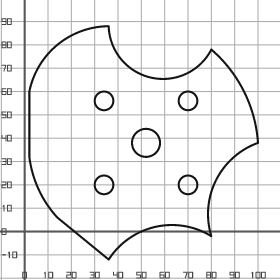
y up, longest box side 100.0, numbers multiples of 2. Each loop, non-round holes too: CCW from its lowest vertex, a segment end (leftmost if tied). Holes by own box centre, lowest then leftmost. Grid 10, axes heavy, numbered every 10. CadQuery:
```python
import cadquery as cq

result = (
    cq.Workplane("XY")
    .moveTo(36.0, -12.0)
    .threePointArc((56.0, 2.0), (80.0, -2.0))
    .threePointArc((82.0, 22.0), (100.0, 38.0))
    .threePointArc((94.0, 60.0), (80.0, 78.0))
    .threePointArc((54.0, 66.0), (36.0, 88.0))
    .threePointArc((14.0, 80.0), (2.0, 60.0))
    .lineTo(2.0, 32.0)
    .threePointArc((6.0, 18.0), (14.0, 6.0))
    .close()
    .moveTo(34.0, 20.0)
    .circle(4.0)
    .moveTo(70.0, 20.0)
    .circle(4.0)
    .moveTo(52.0, 38.0)
    .circle(6.0)
    .moveTo(34.0, 56.0)
    .circle(4.0)
    .moveTo(70.0, 56.0)
    .circle(4.0)
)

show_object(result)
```